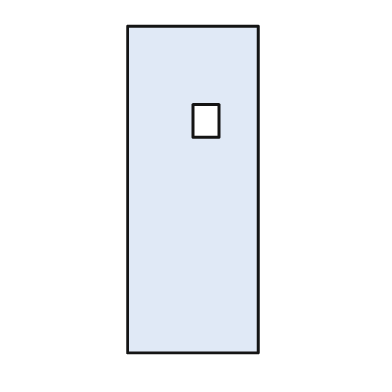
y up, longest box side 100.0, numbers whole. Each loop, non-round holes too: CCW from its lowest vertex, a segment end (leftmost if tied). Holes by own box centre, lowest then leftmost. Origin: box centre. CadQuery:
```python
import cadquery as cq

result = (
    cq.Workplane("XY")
    .moveTo(-20.0, -50.0)
    .lineTo(20.0, -50.0)
    .lineTo(20.0, 50.0)
    .lineTo(-20.0, 50.0)
    .close()
    .moveTo(0.0, 16.0)
    .lineTo(8.0, 16.0)
    .lineTo(8.0, 26.0)
    .lineTo(0.0, 26.0)
    .close()
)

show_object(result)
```